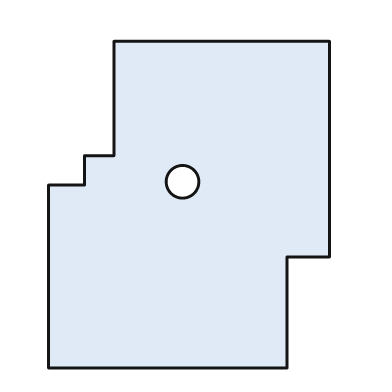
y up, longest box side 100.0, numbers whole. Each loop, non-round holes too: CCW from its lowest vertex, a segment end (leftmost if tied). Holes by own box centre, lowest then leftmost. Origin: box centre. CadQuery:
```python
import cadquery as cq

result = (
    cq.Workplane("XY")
    .moveTo(-43.0, -50.0)
    .lineTo(30.0, -50.0)
    .lineTo(30.0, -16.0)
    .lineTo(43.0, -16.0)
    .lineTo(43.0, 50.0)
    .lineTo(-23.0, 50.0)
    .lineTo(-23.0, 15.0)
    .lineTo(-32.0, 15.0)
    .lineTo(-32.0, 6.0)
    .lineTo(-43.0, 6.0)
    .close()
    .moveTo(-2.0, 7.0)
    .circle(5.0)
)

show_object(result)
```